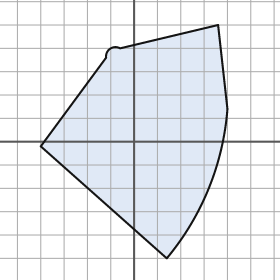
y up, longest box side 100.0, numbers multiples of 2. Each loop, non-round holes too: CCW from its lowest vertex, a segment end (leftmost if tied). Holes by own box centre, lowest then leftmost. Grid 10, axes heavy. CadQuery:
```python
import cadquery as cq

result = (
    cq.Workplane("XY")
    .moveTo(14.0, -50.0)
    .threePointArc((32.0, -20.0), (40.0, 14.0))
    .lineTo(36.0, 50.0)
    .lineTo(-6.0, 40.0)
    .threePointArc((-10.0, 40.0), (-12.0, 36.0))
    .lineTo(-40.0, -2.0)
    .close()
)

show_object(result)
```